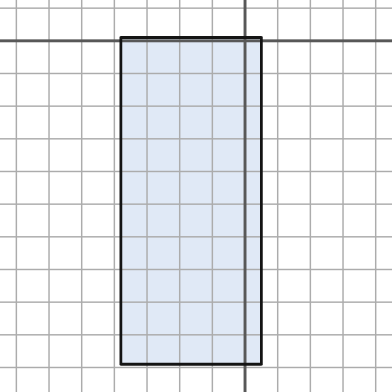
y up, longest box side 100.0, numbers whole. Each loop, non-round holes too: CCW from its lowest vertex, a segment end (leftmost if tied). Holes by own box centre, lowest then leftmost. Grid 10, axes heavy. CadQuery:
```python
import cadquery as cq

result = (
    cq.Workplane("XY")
    .moveTo(-38.0, -99.0)
    .lineTo(5.0, -99.0)
    .lineTo(5.0, 1.0)
    .lineTo(-38.0, 1.0)
    .close()
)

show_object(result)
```